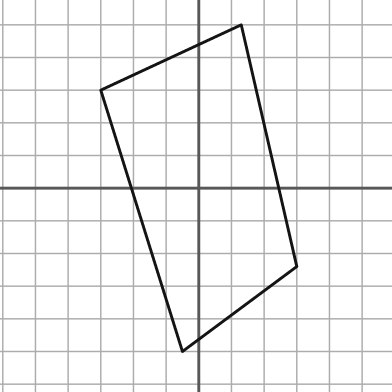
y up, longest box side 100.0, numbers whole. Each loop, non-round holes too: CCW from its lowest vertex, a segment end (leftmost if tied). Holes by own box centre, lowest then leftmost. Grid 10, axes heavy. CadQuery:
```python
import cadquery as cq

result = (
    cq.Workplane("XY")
    .moveTo(-5.0, -50.0)
    .lineTo(30.0, -24.0)
    .lineTo(13.0, 50.0)
    .lineTo(-30.0, 30.0)
    .close()
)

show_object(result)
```